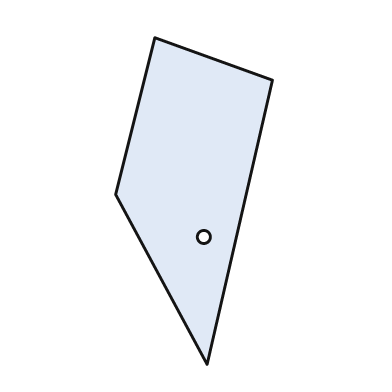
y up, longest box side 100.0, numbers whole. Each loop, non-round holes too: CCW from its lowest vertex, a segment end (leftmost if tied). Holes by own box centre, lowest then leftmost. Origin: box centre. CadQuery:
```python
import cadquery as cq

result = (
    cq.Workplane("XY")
    .moveTo(4.0, -50.0)
    .lineTo(24.0, 37.0)
    .lineTo(-12.0, 50.0)
    .lineTo(-24.0, 2.0)
    .close()
    .moveTo(3.0, -11.0)
    .circle(2.0)
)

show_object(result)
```